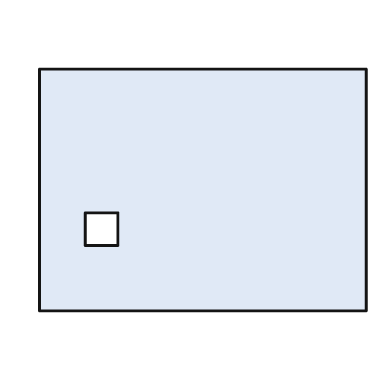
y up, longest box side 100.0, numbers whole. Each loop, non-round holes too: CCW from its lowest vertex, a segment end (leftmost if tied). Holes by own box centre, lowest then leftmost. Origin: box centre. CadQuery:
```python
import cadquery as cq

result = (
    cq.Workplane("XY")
    .moveTo(-50.0, -37.0)
    .lineTo(50.0, -37.0)
    .lineTo(50.0, 37.0)
    .lineTo(-50.0, 37.0)
    .close()
    .moveTo(-36.0, -17.0)
    .lineTo(-26.0, -17.0)
    .lineTo(-26.0, -7.0)
    .lineTo(-36.0, -7.0)
    .close()
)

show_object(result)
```